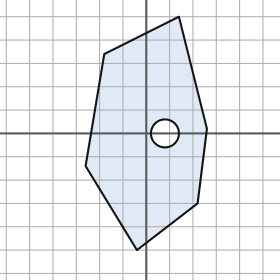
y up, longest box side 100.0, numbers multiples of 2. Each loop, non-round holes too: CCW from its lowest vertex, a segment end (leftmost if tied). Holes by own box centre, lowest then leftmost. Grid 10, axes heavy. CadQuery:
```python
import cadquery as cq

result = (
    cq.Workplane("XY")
    .moveTo(-4.0, -50.0)
    .lineTo(22.0, -30.0)
    .lineTo(26.0, 2.0)
    .lineTo(14.0, 50.0)
    .lineTo(-18.0, 34.0)
    .lineTo(-26.0, -14.0)
    .close()
    .moveTo(8.0, 0.0)
    .circle(6.0)
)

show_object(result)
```